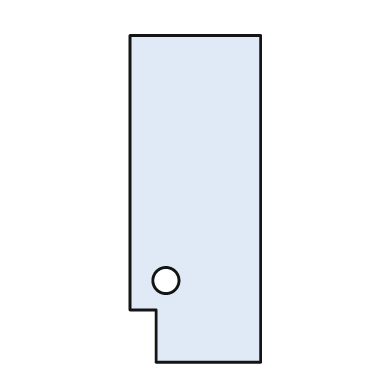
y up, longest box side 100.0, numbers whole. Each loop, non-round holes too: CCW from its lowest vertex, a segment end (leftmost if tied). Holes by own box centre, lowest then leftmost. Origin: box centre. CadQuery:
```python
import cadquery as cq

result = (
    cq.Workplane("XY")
    .moveTo(-12.0, -50.0)
    .lineTo(20.0, -50.0)
    .lineTo(20.0, 50.0)
    .lineTo(-20.0, 50.0)
    .lineTo(-20.0, -34.0)
    .lineTo(-12.0, -34.0)
    .close()
    .moveTo(-9.0, -25.0)
    .circle(4.0)
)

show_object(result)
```